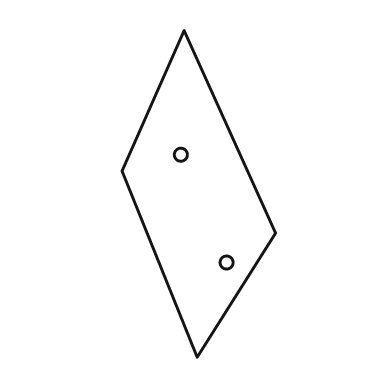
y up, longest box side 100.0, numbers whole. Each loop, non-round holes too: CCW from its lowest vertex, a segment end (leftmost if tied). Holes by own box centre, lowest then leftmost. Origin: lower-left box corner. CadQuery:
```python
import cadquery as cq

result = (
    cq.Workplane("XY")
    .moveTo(23.0, 0.0)
    .lineTo(47.0, 38.0)
    .lineTo(19.0, 100.0)
    .lineTo(0.0, 57.0)
    .close()
    .moveTo(32.0, 29.0)
    .circle(2.0)
    .moveTo(18.0, 62.0)
    .circle(2.0)
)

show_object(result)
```